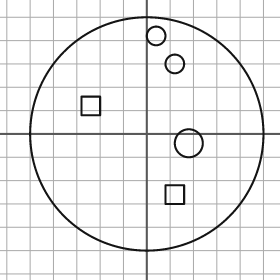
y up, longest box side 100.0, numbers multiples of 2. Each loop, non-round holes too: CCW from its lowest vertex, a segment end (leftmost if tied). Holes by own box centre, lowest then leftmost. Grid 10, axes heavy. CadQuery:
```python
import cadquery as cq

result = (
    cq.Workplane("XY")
    .moveTo(0.0, 0.0)
    .circle(50.0)
    .moveTo(8.0, -30.0)
    .lineTo(16.0, -30.0)
    .lineTo(16.0, -22.0)
    .lineTo(8.0, -22.0)
    .close()
    .moveTo(18.0, -4.0)
    .circle(6.0)
    .moveTo(-28.0, 8.0)
    .lineTo(-20.0, 8.0)
    .lineTo(-20.0, 16.0)
    .lineTo(-28.0, 16.0)
    .close()
    .moveTo(12.0, 30.0)
    .circle(4.0)
    .moveTo(4.0, 42.0)
    .circle(4.0)
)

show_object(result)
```